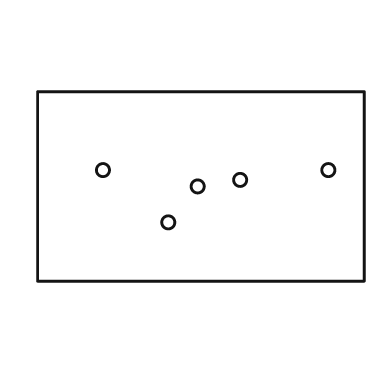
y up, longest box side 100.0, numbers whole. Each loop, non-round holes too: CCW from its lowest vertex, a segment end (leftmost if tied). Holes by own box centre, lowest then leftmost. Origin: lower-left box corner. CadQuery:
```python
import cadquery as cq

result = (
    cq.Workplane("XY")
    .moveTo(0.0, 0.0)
    .lineTo(100.0, 0.0)
    .lineTo(100.0, 58.0)
    .lineTo(0.0, 58.0)
    .close()
    .moveTo(40.0, 18.0)
    .circle(2.0)
    .moveTo(49.0, 29.0)
    .circle(2.0)
    .moveTo(62.0, 31.0)
    .circle(2.0)
    .moveTo(20.0, 34.0)
    .circle(2.0)
    .moveTo(89.0, 34.0)
    .circle(2.0)
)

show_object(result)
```